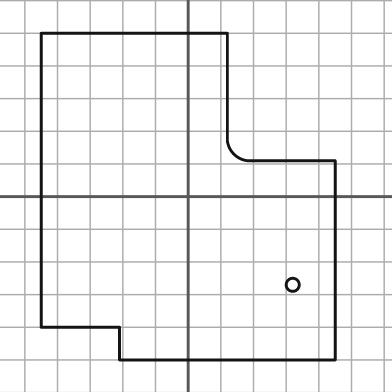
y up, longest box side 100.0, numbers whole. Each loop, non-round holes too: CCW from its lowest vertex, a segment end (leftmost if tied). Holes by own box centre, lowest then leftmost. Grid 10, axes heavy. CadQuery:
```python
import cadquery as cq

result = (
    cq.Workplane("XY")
    .moveTo(-21.0, -50.0)
    .lineTo(45.0, -50.0)
    .lineTo(45.0, 11.0)
    .lineTo(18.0, 11.0)
    .threePointArc((14.0, 13.0), (12.0, 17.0))
    .lineTo(12.0, 50.0)
    .lineTo(-45.0, 50.0)
    .lineTo(-45.0, -40.0)
    .lineTo(-21.0, -40.0)
    .close()
    .moveTo(32.0, -27.0)
    .circle(2.0)
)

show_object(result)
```